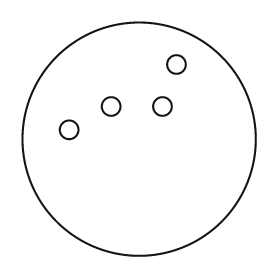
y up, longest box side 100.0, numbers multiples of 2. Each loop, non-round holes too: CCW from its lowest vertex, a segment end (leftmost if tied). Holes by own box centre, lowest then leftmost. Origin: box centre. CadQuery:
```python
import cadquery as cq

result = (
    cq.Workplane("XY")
    .moveTo(0.0, 0.0)
    .circle(50.0)
    .moveTo(-30.0, 4.0)
    .circle(4.0)
    .moveTo(-12.0, 14.0)
    .circle(4.0)
    .moveTo(10.0, 14.0)
    .circle(4.0)
    .moveTo(16.0, 32.0)
    .circle(4.0)
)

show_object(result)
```